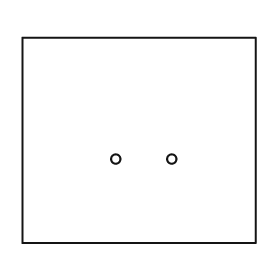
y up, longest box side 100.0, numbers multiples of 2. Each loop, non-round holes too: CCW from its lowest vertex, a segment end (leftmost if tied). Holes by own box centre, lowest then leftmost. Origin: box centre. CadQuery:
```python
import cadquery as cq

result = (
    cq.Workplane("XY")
    .moveTo(-50.0, -44.0)
    .lineTo(50.0, -44.0)
    .lineTo(50.0, 44.0)
    .lineTo(-50.0, 44.0)
    .close()
    .moveTo(-10.0, -8.0)
    .circle(2.0)
    .moveTo(14.0, -8.0)
    .circle(2.0)
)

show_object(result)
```